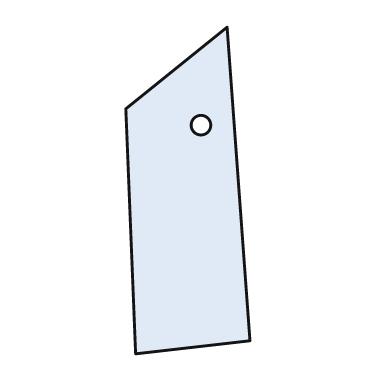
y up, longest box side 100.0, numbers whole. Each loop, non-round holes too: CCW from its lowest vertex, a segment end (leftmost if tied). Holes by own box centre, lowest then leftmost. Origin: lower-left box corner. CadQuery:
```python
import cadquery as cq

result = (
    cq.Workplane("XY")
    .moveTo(3.0, 0.0)
    .lineTo(38.0, 4.0)
    .lineTo(31.0, 100.0)
    .lineTo(0.0, 75.0)
    .close()
    .moveTo(23.0, 70.0)
    .circle(3.0)
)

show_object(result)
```